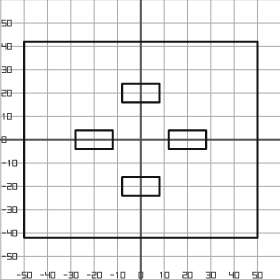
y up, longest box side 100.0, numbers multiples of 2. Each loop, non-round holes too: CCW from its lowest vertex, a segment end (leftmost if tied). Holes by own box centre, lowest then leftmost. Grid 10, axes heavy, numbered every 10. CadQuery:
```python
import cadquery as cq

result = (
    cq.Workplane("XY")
    .moveTo(-50.0, -42.0)
    .lineTo(50.0, -42.0)
    .lineTo(50.0, 42.0)
    .lineTo(-50.0, 42.0)
    .close()
    .moveTo(-8.0, -24.0)
    .lineTo(8.0, -24.0)
    .lineTo(8.0, -16.0)
    .lineTo(-8.0, -16.0)
    .close()
    .moveTo(-28.0, -4.0)
    .lineTo(-12.0, -4.0)
    .lineTo(-12.0, 4.0)
    .lineTo(-28.0, 4.0)
    .close()
    .moveTo(12.0, -4.0)
    .lineTo(28.0, -4.0)
    .lineTo(28.0, 4.0)
    .lineTo(12.0, 4.0)
    .close()
    .moveTo(-8.0, 16.0)
    .lineTo(8.0, 16.0)
    .lineTo(8.0, 24.0)
    .lineTo(-8.0, 24.0)
    .close()
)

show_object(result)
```